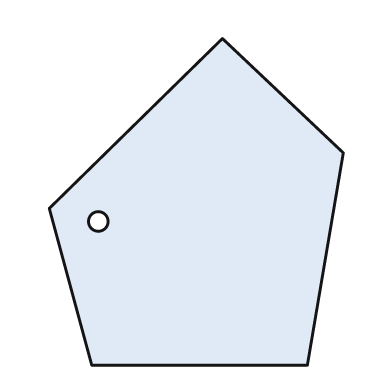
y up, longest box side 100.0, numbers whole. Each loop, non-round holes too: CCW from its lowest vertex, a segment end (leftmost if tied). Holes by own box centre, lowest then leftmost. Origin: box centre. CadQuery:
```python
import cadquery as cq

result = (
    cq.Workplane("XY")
    .moveTo(-32.0, -50.0)
    .lineTo(34.0, -50.0)
    .lineTo(45.0, 15.0)
    .lineTo(8.0, 50.0)
    .lineTo(-45.0, -2.0)
    .close()
    .moveTo(-30.0, -6.0)
    .circle(3.0)
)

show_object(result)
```